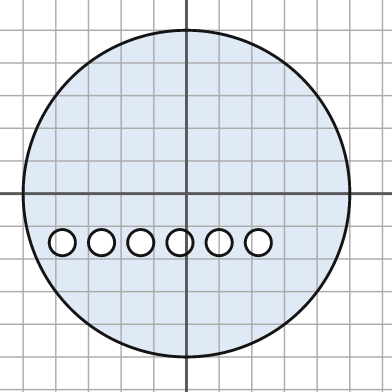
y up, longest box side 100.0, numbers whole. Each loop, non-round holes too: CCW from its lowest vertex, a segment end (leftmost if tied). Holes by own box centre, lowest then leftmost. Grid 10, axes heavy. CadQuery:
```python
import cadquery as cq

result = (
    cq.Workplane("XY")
    .moveTo(0.0, 0.0)
    .circle(50.0)
    .moveTo(-38.0, -15.0)
    .circle(4.0)
    .moveTo(-26.0, -15.0)
    .circle(4.0)
    .moveTo(-14.0, -15.0)
    .circle(4.0)
    .moveTo(-2.0, -15.0)
    .circle(4.0)
    .moveTo(10.0, -15.0)
    .circle(4.0)
    .moveTo(22.0, -15.0)
    .circle(4.0)
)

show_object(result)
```